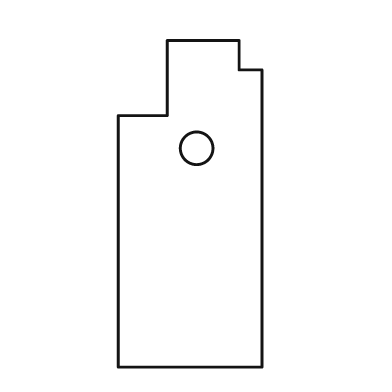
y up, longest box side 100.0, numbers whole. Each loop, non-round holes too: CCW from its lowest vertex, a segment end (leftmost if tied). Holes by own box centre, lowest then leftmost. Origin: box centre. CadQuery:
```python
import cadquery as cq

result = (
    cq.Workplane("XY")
    .moveTo(-22.0, -50.0)
    .lineTo(22.0, -50.0)
    .lineTo(22.0, 41.0)
    .lineTo(15.0, 41.0)
    .lineTo(15.0, 50.0)
    .lineTo(-7.0, 50.0)
    .lineTo(-7.0, 27.0)
    .lineTo(-22.0, 27.0)
    .close()
    .moveTo(2.0, 17.0)
    .circle(5.0)
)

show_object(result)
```